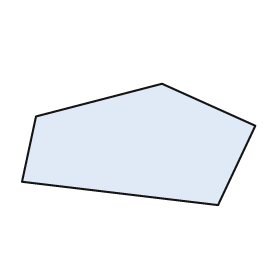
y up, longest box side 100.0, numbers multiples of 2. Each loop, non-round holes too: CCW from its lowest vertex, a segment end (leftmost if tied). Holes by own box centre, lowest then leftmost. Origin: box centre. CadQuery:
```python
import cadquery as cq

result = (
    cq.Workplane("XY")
    .moveTo(34.0, -26.0)
    .lineTo(50.0, 8.0)
    .lineTo(10.0, 26.0)
    .lineTo(-44.0, 12.0)
    .lineTo(-50.0, -16.0)
    .close()
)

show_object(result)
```